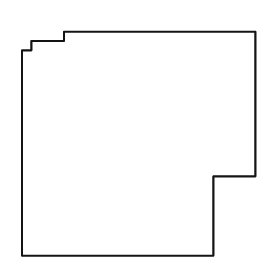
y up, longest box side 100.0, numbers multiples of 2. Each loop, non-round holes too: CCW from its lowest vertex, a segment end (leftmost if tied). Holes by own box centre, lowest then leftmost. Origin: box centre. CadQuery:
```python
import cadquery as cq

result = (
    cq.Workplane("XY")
    .moveTo(-50.0, -48.0)
    .lineTo(32.0, -48.0)
    .lineTo(32.0, -14.0)
    .lineTo(50.0, -14.0)
    .lineTo(50.0, 48.0)
    .lineTo(-32.0, 48.0)
    .lineTo(-32.0, 44.0)
    .lineTo(-46.0, 44.0)
    .lineTo(-46.0, 40.0)
    .lineTo(-50.0, 40.0)
    .close()
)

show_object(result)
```